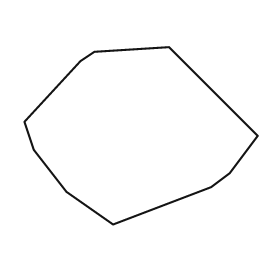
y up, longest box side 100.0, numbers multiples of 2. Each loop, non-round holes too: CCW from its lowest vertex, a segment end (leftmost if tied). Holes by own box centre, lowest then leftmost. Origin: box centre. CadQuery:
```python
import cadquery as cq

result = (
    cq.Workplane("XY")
    .moveTo(-12.0, -38.0)
    .lineTo(30.0, -22.0)
    .lineTo(38.0, -16.0)
    .lineTo(50.0, 0.0)
    .lineTo(12.0, 38.0)
    .lineTo(-20.0, 36.0)
    .lineTo(-26.0, 32.0)
    .lineTo(-50.0, 6.0)
    .lineTo(-46.0, -6.0)
    .lineTo(-32.0, -24.0)
    .close()
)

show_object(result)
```